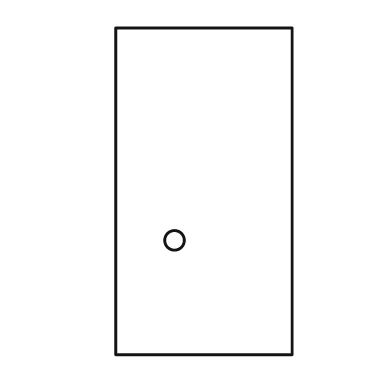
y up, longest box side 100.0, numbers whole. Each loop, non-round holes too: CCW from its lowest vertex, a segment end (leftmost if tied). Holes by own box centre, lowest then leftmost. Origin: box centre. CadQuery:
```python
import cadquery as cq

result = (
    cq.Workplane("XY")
    .moveTo(-27.0, -50.0)
    .lineTo(27.0, -50.0)
    .lineTo(27.0, 50.0)
    .lineTo(-27.0, 50.0)
    .close()
    .moveTo(-9.0, -15.0)
    .circle(3.0)
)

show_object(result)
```